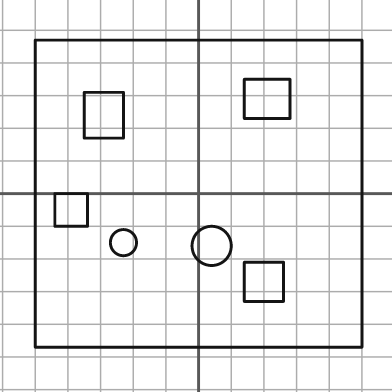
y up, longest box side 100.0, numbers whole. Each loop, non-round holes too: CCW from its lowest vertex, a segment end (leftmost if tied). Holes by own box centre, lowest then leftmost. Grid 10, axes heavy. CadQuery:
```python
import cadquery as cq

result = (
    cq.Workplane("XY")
    .moveTo(-50.0, -47.0)
    .lineTo(50.0, -47.0)
    .lineTo(50.0, 47.0)
    .lineTo(-50.0, 47.0)
    .close()
    .moveTo(14.0, -33.0)
    .lineTo(26.0, -33.0)
    .lineTo(26.0, -21.0)
    .lineTo(14.0, -21.0)
    .close()
    .moveTo(4.0, -16.0)
    .circle(6.0)
    .moveTo(-23.0, -15.0)
    .circle(4.0)
    .moveTo(-44.0, -10.0)
    .lineTo(-34.0, -10.0)
    .lineTo(-34.0, 0.0)
    .lineTo(-44.0, 0.0)
    .close()
    .moveTo(-35.0, 17.0)
    .lineTo(-23.0, 17.0)
    .lineTo(-23.0, 31.0)
    .lineTo(-35.0, 31.0)
    .close()
    .moveTo(14.0, 23.0)
    .lineTo(28.0, 23.0)
    .lineTo(28.0, 35.0)
    .lineTo(14.0, 35.0)
    .close()
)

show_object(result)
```